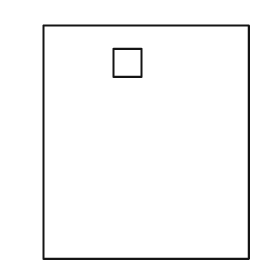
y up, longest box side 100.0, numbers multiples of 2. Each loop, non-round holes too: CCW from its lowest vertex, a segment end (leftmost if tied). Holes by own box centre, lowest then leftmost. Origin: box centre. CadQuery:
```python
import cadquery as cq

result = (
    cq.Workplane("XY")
    .moveTo(-44.0, -50.0)
    .lineTo(44.0, -50.0)
    .lineTo(44.0, 50.0)
    .lineTo(-44.0, 50.0)
    .close()
    .moveTo(-14.0, 28.0)
    .lineTo(-2.0, 28.0)
    .lineTo(-2.0, 40.0)
    .lineTo(-14.0, 40.0)
    .close()
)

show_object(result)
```